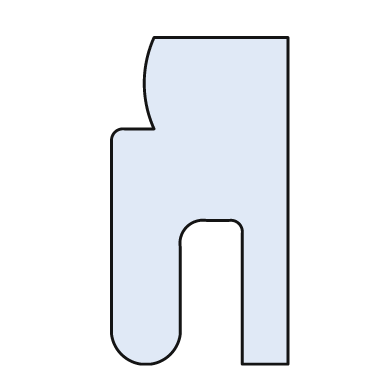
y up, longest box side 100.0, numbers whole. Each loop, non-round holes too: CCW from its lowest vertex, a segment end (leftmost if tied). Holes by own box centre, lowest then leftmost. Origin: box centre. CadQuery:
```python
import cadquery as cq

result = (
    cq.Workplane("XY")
    .moveTo(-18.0, -50.0)
    .lineTo(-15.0, -50.0)
    .threePointArc((-9.0, -47.0), (-6.0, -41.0))
    .lineTo(-6.0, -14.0)
    .threePointArc((-4.0, -8.0), (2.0, -6.0))
    .lineTo(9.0, -6.0)
    .threePointArc((12.0, -7.0), (13.0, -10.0))
    .lineTo(13.0, -50.0)
    .lineTo(27.0, -50.0)
    .lineTo(27.0, 50.0)
    .lineTo(-14.0, 50.0)
    .threePointArc((-17.0, 36.0), (-14.0, 22.0))
    .lineTo(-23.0, 22.0)
    .threePointArc((-26.0, 21.0), (-27.0, 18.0))
    .lineTo(-27.0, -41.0)
    .threePointArc((-24.0, -47.0), (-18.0, -50.0))
    .close()
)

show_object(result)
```